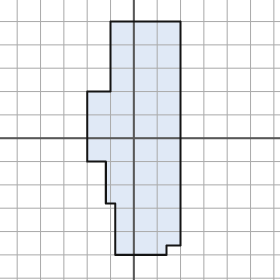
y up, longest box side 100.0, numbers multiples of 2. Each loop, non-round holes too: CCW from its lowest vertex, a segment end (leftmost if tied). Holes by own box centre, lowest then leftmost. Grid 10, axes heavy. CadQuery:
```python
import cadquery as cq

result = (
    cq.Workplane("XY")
    .moveTo(-8.0, -50.0)
    .lineTo(14.0, -50.0)
    .lineTo(14.0, -46.0)
    .lineTo(20.0, -46.0)
    .lineTo(20.0, 50.0)
    .lineTo(-10.0, 50.0)
    .lineTo(-10.0, 20.0)
    .lineTo(-20.0, 20.0)
    .lineTo(-20.0, -10.0)
    .lineTo(-12.0, -10.0)
    .lineTo(-12.0, -28.0)
    .lineTo(-8.0, -28.0)
    .close()
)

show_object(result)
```